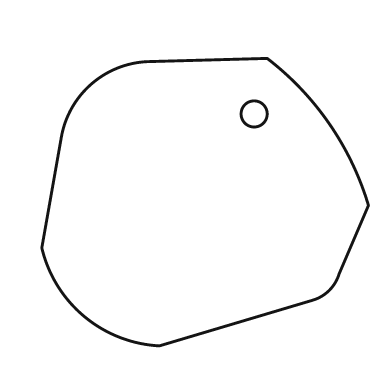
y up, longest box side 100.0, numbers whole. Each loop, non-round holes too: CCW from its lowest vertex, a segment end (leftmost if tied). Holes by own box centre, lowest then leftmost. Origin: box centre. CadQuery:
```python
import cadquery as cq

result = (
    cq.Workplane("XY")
    .moveTo(-14.0, -44.0)
    .lineTo(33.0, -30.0)
    .threePointArc((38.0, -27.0), (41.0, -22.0))
    .lineTo(50.0, -1.0)
    .threePointArc((38.0, 24.0), (19.0, 44.0))
    .lineTo(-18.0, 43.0)
    .threePointArc((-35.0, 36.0), (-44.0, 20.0))
    .lineTo(-50.0, -14.0)
    .threePointArc((-37.0, -35.0), (-14.0, -44.0))
    .close()
    .moveTo(15.0, 27.0)
    .circle(4.0)
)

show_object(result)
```